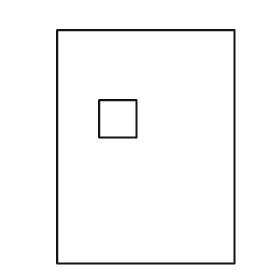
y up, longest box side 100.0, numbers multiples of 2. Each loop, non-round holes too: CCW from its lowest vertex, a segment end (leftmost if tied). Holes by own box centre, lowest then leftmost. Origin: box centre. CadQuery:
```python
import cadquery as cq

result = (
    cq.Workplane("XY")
    .moveTo(-38.0, -50.0)
    .lineTo(38.0, -50.0)
    .lineTo(38.0, 50.0)
    .lineTo(-38.0, 50.0)
    .close()
    .moveTo(-20.0, 4.0)
    .lineTo(-4.0, 4.0)
    .lineTo(-4.0, 20.0)
    .lineTo(-20.0, 20.0)
    .close()
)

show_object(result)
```